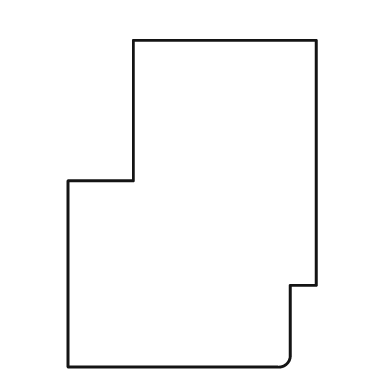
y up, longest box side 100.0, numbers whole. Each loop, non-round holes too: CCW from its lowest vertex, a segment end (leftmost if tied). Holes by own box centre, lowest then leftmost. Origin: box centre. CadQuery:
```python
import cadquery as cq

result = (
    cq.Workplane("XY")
    .moveTo(-38.0, -50.0)
    .lineTo(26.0, -50.0)
    .threePointArc((29.0, -49.0), (30.0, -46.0))
    .lineTo(30.0, -25.0)
    .lineTo(38.0, -25.0)
    .lineTo(38.0, 50.0)
    .lineTo(-18.0, 50.0)
    .lineTo(-18.0, 7.0)
    .lineTo(-38.0, 7.0)
    .close()
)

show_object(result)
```